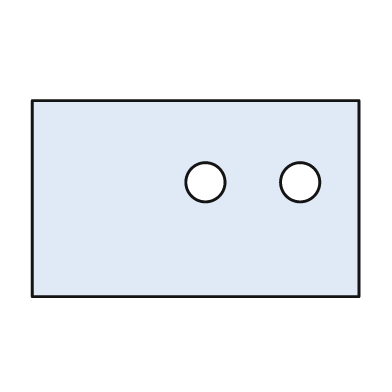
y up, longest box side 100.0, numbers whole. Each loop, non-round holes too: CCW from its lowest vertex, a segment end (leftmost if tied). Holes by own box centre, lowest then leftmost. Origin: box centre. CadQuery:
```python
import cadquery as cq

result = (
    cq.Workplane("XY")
    .moveTo(-50.0, -30.0)
    .lineTo(50.0, -30.0)
    .lineTo(50.0, 30.0)
    .lineTo(-50.0, 30.0)
    .close()
    .moveTo(3.0, 5.0)
    .circle(6.0)
    .moveTo(32.0, 5.0)
    .circle(6.0)
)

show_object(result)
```